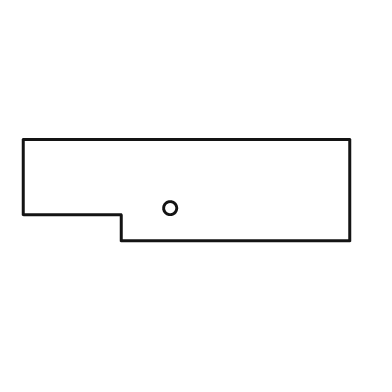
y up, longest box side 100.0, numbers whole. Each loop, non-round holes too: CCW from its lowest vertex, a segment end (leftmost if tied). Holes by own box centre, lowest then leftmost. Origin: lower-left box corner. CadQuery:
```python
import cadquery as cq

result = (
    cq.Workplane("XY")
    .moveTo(30.0, 0.0)
    .lineTo(100.0, 0.0)
    .lineTo(100.0, 31.0)
    .lineTo(0.0, 31.0)
    .lineTo(0.0, 8.0)
    .lineTo(30.0, 8.0)
    .close()
    .moveTo(45.0, 10.0)
    .circle(2.0)
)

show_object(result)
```